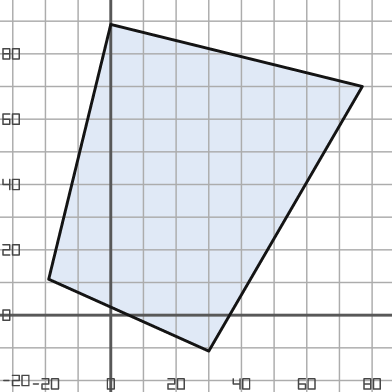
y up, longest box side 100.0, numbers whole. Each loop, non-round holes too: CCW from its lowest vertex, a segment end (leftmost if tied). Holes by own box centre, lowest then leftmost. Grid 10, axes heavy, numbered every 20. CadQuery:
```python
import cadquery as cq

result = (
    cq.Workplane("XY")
    .moveTo(30.0, -11.0)
    .lineTo(77.0, 70.0)
    .lineTo(0.0, 89.0)
    .lineTo(-19.0, 11.0)
    .close()
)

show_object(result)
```